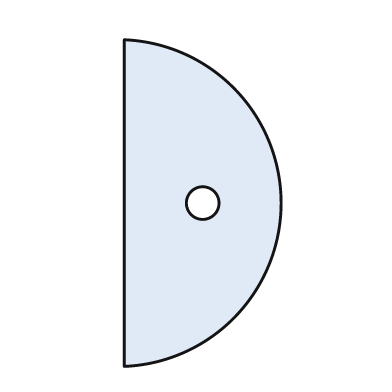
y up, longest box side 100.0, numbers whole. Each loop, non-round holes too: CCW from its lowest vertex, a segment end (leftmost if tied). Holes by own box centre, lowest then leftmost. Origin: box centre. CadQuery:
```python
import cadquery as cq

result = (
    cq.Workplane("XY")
    .moveTo(-24.0, -50.0)
    .threePointArc((24.0, 0.0), (-24.0, 50.0))
    .close()
    .moveTo(0.0, 0.0)
    .circle(5.0)
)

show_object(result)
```